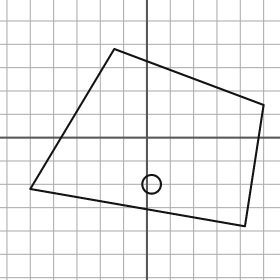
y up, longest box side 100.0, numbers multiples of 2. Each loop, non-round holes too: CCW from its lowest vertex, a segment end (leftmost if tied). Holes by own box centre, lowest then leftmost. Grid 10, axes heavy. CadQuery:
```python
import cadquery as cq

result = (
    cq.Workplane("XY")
    .moveTo(42.0, -38.0)
    .lineTo(50.0, 14.0)
    .lineTo(-14.0, 38.0)
    .lineTo(-50.0, -22.0)
    .close()
    .moveTo(2.0, -20.0)
    .circle(4.0)
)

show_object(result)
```